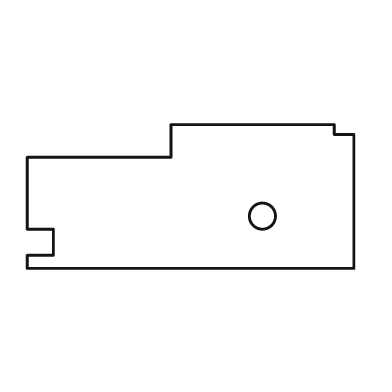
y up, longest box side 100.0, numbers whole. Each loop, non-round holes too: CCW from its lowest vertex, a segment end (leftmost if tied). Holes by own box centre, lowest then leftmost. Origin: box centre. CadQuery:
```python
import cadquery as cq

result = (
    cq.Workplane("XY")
    .moveTo(-50.0, -22.0)
    .lineTo(50.0, -22.0)
    .lineTo(50.0, 19.0)
    .lineTo(44.0, 19.0)
    .lineTo(44.0, 22.0)
    .lineTo(-6.0, 22.0)
    .lineTo(-6.0, 12.0)
    .lineTo(-50.0, 12.0)
    .lineTo(-50.0, -10.0)
    .lineTo(-42.0, -10.0)
    .lineTo(-42.0, -18.0)
    .lineTo(-50.0, -18.0)
    .close()
    .moveTo(22.0, -6.0)
    .circle(4.0)
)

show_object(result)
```